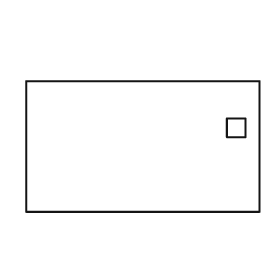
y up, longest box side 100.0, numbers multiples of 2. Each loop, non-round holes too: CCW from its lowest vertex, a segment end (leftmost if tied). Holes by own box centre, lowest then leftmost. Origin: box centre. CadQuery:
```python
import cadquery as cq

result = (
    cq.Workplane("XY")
    .moveTo(-50.0, -28.0)
    .lineTo(50.0, -28.0)
    .lineTo(50.0, 28.0)
    .lineTo(-50.0, 28.0)
    .close()
    .moveTo(36.0, 4.0)
    .lineTo(44.0, 4.0)
    .lineTo(44.0, 12.0)
    .lineTo(36.0, 12.0)
    .close()
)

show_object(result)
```